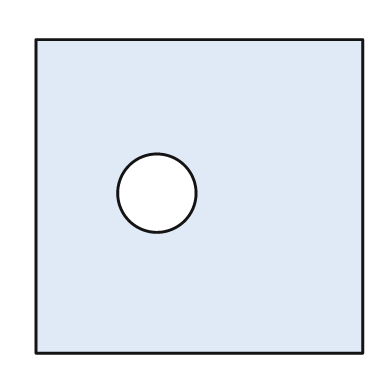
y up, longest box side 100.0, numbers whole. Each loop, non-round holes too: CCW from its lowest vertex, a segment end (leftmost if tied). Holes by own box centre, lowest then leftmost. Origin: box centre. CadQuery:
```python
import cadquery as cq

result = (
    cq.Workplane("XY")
    .moveTo(-50.0, -48.0)
    .lineTo(50.0, -48.0)
    .lineTo(50.0, 48.0)
    .lineTo(-50.0, 48.0)
    .close()
    .moveTo(-13.0, 1.0)
    .circle(12.0)
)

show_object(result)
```